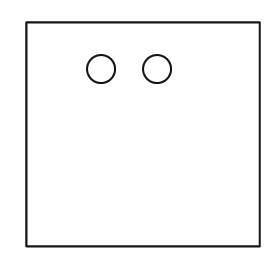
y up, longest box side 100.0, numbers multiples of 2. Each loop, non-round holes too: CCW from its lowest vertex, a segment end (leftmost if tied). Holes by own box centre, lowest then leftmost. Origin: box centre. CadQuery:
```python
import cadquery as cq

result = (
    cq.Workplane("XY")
    .moveTo(-50.0, -48.0)
    .lineTo(50.0, -48.0)
    .lineTo(50.0, 48.0)
    .lineTo(-50.0, 48.0)
    .close()
    .moveTo(-18.0, 28.0)
    .circle(6.0)
    .moveTo(6.0, 28.0)
    .circle(6.0)
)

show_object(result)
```